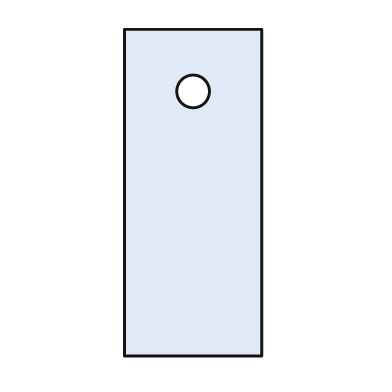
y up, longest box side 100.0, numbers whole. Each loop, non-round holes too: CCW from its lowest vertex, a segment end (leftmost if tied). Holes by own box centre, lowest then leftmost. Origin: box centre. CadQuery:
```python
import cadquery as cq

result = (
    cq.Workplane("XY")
    .moveTo(-21.0, -50.0)
    .lineTo(21.0, -50.0)
    .lineTo(21.0, 50.0)
    .lineTo(-21.0, 50.0)
    .close()
    .moveTo(0.0, 31.0)
    .circle(5.0)
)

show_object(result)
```